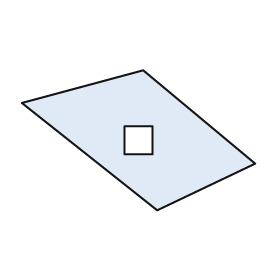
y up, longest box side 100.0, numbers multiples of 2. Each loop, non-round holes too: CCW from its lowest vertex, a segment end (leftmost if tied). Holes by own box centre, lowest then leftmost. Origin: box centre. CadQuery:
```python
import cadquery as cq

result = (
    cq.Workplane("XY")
    .moveTo(8.0, -30.0)
    .lineTo(50.0, -10.0)
    .lineTo(2.0, 30.0)
    .lineTo(-50.0, 16.0)
    .close()
    .moveTo(-6.0, -6.0)
    .lineTo(6.0, -6.0)
    .lineTo(6.0, 6.0)
    .lineTo(-6.0, 6.0)
    .close()
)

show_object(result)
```